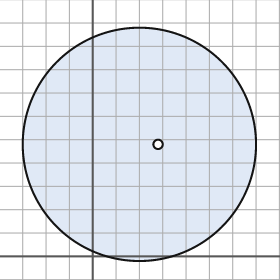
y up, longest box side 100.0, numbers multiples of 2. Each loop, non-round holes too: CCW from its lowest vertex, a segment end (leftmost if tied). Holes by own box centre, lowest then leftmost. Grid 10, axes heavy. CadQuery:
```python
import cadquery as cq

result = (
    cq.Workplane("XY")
    .moveTo(20.0, 48.0)
    .circle(50.0)
    .moveTo(28.0, 48.0)
    .circle(2.0)
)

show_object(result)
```